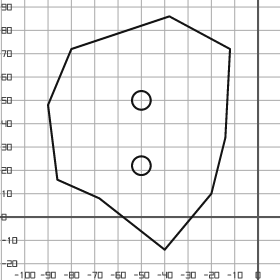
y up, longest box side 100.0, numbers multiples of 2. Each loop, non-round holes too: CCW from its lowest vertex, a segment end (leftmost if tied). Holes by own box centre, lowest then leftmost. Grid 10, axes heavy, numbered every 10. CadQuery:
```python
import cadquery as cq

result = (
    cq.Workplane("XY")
    .moveTo(-40.0, -14.0)
    .lineTo(-20.0, 10.0)
    .lineTo(-14.0, 34.0)
    .lineTo(-12.0, 72.0)
    .lineTo(-38.0, 86.0)
    .lineTo(-80.0, 72.0)
    .lineTo(-90.0, 48.0)
    .lineTo(-86.0, 16.0)
    .lineTo(-68.0, 8.0)
    .close()
    .moveTo(-50.0, 22.0)
    .circle(4.0)
    .moveTo(-50.0, 50.0)
    .circle(4.0)
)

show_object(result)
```